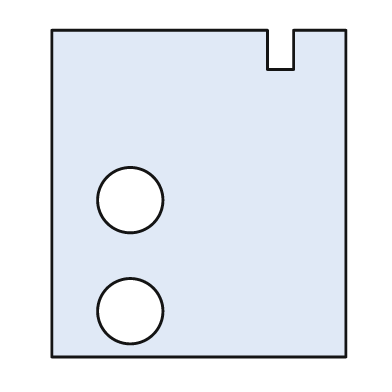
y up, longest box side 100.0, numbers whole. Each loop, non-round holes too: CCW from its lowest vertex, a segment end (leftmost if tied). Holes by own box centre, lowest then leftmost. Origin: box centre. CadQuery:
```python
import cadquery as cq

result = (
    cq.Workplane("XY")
    .moveTo(-45.0, -50.0)
    .lineTo(45.0, -50.0)
    .lineTo(45.0, 50.0)
    .lineTo(29.0, 50.0)
    .lineTo(29.0, 38.0)
    .lineTo(21.0, 38.0)
    .lineTo(21.0, 50.0)
    .lineTo(-45.0, 50.0)
    .close()
    .moveTo(-21.0, -36.0)
    .circle(10.0)
    .moveTo(-21.0, -2.0)
    .circle(10.0)
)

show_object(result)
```